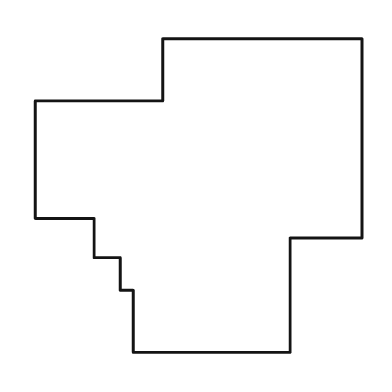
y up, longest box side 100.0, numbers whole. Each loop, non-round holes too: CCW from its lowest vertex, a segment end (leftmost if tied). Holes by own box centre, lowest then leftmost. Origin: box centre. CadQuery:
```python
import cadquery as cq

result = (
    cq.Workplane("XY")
    .moveTo(-20.0, -48.0)
    .lineTo(28.0, -48.0)
    .lineTo(28.0, -13.0)
    .lineTo(50.0, -13.0)
    .lineTo(50.0, 48.0)
    .lineTo(-11.0, 48.0)
    .lineTo(-11.0, 29.0)
    .lineTo(-50.0, 29.0)
    .lineTo(-50.0, -7.0)
    .lineTo(-32.0, -7.0)
    .lineTo(-32.0, -19.0)
    .lineTo(-24.0, -19.0)
    .lineTo(-24.0, -29.0)
    .lineTo(-20.0, -29.0)
    .close()
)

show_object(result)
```